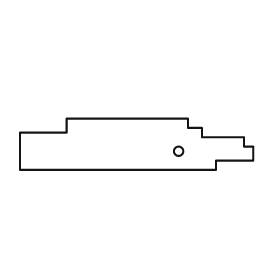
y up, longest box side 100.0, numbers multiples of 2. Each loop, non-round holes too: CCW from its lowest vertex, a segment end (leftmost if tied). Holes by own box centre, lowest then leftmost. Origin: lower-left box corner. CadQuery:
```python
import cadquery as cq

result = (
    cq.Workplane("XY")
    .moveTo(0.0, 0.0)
    .lineTo(84.0, 0.0)
    .lineTo(84.0, 4.0)
    .lineTo(100.0, 4.0)
    .lineTo(100.0, 10.0)
    .lineTo(96.0, 10.0)
    .lineTo(96.0, 14.0)
    .lineTo(78.0, 14.0)
    .lineTo(78.0, 18.0)
    .lineTo(72.0, 18.0)
    .lineTo(72.0, 22.0)
    .lineTo(20.0, 22.0)
    .lineTo(20.0, 16.0)
    .lineTo(0.0, 16.0)
    .close()
    .moveTo(68.0, 8.0)
    .circle(2.0)
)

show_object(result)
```